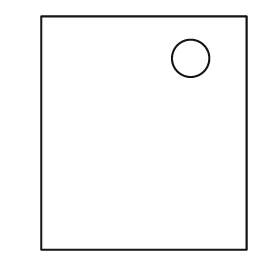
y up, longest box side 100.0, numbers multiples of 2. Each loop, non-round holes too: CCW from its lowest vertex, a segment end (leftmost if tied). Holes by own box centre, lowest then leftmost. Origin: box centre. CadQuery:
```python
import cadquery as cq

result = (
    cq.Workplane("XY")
    .moveTo(-44.0, -50.0)
    .lineTo(44.0, -50.0)
    .lineTo(44.0, 50.0)
    .lineTo(-44.0, 50.0)
    .close()
    .moveTo(20.0, 32.0)
    .circle(8.0)
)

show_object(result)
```